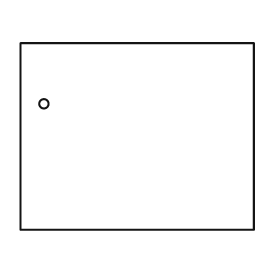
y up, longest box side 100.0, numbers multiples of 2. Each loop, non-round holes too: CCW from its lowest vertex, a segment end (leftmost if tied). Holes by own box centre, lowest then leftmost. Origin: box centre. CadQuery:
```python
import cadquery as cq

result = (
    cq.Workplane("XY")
    .moveTo(-50.0, -40.0)
    .lineTo(50.0, -40.0)
    .lineTo(50.0, 40.0)
    .lineTo(-50.0, 40.0)
    .close()
    .moveTo(-40.0, 14.0)
    .circle(2.0)
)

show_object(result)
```